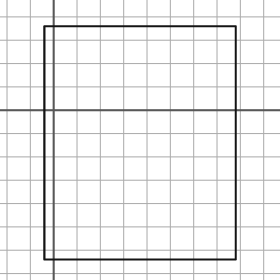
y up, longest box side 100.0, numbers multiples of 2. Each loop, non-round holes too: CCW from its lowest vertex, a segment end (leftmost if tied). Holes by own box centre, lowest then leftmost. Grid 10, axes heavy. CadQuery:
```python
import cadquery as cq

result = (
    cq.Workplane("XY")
    .moveTo(-4.0, -64.0)
    .lineTo(78.0, -64.0)
    .lineTo(78.0, 36.0)
    .lineTo(-4.0, 36.0)
    .close()
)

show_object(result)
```